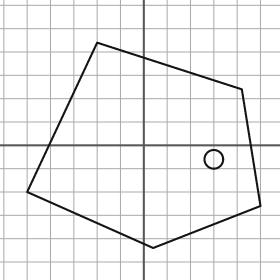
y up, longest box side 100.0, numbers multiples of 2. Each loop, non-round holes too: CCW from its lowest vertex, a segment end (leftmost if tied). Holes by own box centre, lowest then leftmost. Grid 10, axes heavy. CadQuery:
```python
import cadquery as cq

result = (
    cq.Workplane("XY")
    .moveTo(4.0, -44.0)
    .lineTo(50.0, -26.0)
    .lineTo(42.0, 24.0)
    .lineTo(-20.0, 44.0)
    .lineTo(-50.0, -20.0)
    .close()
    .moveTo(30.0, -6.0)
    .circle(4.0)
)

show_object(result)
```